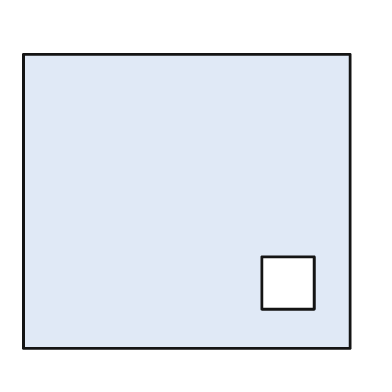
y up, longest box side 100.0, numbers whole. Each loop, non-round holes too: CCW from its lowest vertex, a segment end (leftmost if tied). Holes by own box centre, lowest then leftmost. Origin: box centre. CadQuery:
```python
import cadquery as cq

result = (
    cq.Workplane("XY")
    .moveTo(-50.0, -45.0)
    .lineTo(50.0, -45.0)
    .lineTo(50.0, 45.0)
    .lineTo(-50.0, 45.0)
    .close()
    .moveTo(23.0, -33.0)
    .lineTo(39.0, -33.0)
    .lineTo(39.0, -17.0)
    .lineTo(23.0, -17.0)
    .close()
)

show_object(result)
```